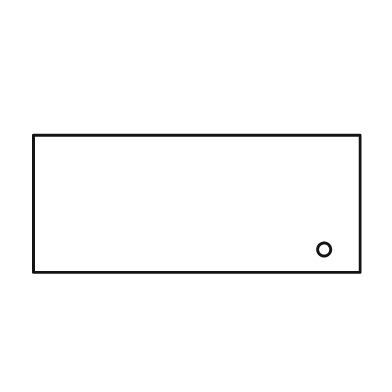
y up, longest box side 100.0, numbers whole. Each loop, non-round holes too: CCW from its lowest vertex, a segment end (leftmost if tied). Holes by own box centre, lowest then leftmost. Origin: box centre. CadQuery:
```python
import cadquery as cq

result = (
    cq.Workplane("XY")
    .moveTo(-50.0, -21.0)
    .lineTo(50.0, -21.0)
    .lineTo(50.0, 21.0)
    .lineTo(-50.0, 21.0)
    .close()
    .moveTo(39.0, -14.0)
    .circle(2.0)
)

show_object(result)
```